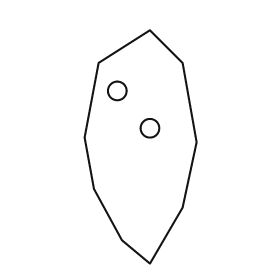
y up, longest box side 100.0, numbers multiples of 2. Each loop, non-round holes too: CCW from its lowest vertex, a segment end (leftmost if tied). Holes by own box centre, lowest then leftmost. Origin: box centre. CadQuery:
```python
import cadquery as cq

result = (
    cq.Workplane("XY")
    .moveTo(4.0, -50.0)
    .lineTo(18.0, -26.0)
    .lineTo(24.0, 2.0)
    .lineTo(18.0, 36.0)
    .lineTo(4.0, 50.0)
    .lineTo(-18.0, 36.0)
    .lineTo(-24.0, 4.0)
    .lineTo(-20.0, -18.0)
    .lineTo(-8.0, -40.0)
    .close()
    .moveTo(4.0, 8.0)
    .circle(4.0)
    .moveTo(-10.0, 24.0)
    .circle(4.0)
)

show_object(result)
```